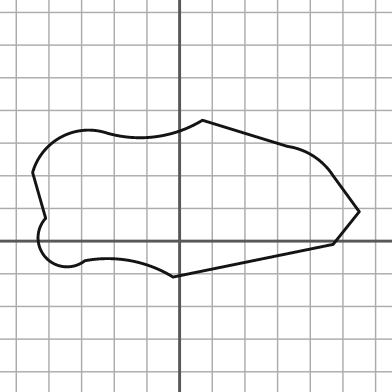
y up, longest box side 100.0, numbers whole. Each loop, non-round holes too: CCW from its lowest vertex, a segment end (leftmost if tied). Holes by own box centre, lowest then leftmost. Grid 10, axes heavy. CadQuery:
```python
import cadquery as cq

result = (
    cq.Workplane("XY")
    .moveTo(-2.0, -11.0)
    .lineTo(47.0, -1.0)
    .lineTo(55.0, 9.0)
    .lineTo(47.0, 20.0)
    .threePointArc((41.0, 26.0), (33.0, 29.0))
    .lineTo(7.0, 37.0)
    .threePointArc((-7.0, 32.0), (-22.0, 33.0))
    .threePointArc((-36.0, 32.0), (-45.0, 21.0))
    .lineTo(-41.0, 7.0)
    .threePointArc((-41.0, -5.0), (-29.0, -6.0))
    .threePointArc((-15.0, -6.0), (-2.0, -11.0))
    .close()
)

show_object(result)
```